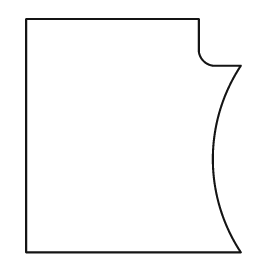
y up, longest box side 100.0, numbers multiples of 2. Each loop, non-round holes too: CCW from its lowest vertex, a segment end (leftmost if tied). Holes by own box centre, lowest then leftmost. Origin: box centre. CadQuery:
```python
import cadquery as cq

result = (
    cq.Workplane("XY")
    .moveTo(-46.0, -50.0)
    .lineTo(46.0, -50.0)
    .threePointArc((34.0, -10.0), (46.0, 30.0))
    .lineTo(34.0, 30.0)
    .threePointArc((30.0, 32.0), (28.0, 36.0))
    .lineTo(28.0, 50.0)
    .lineTo(-46.0, 50.0)
    .close()
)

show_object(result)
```